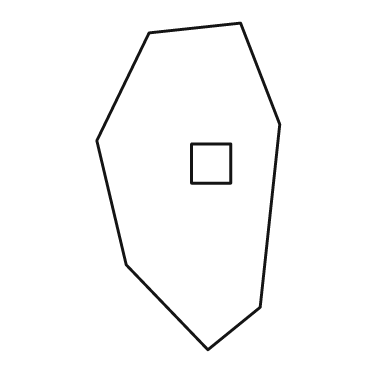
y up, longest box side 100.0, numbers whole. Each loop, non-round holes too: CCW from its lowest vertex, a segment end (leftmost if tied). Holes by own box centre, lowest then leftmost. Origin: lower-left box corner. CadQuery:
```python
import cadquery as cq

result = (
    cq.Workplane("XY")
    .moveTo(34.0, 0.0)
    .lineTo(50.0, 13.0)
    .lineTo(56.0, 69.0)
    .lineTo(44.0, 100.0)
    .lineTo(16.0, 97.0)
    .lineTo(0.0, 64.0)
    .lineTo(9.0, 26.0)
    .close()
    .moveTo(29.0, 51.0)
    .lineTo(41.0, 51.0)
    .lineTo(41.0, 63.0)
    .lineTo(29.0, 63.0)
    .close()
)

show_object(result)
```